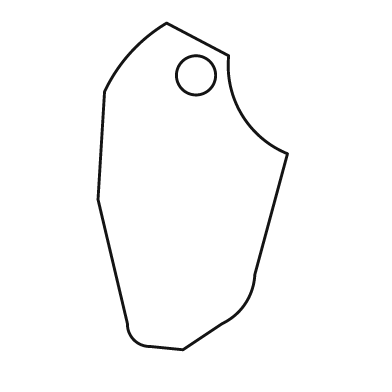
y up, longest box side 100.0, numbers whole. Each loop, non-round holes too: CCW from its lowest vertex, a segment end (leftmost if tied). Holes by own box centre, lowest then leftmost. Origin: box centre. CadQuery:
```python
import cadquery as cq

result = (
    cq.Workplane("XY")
    .moveTo(-3.0, -50.0)
    .lineTo(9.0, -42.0)
    .threePointArc((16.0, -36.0), (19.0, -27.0))
    .lineTo(29.0, 10.0)
    .threePointArc((15.0, 22.0), (11.0, 40.0))
    .lineTo(-8.0, 50.0)
    .threePointArc((-19.0, 41.0), (-27.0, 29.0))
    .lineTo(-29.0, -4.0)
    .lineTo(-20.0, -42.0)
    .threePointArc((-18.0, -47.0), (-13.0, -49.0))
    .close()
    .moveTo(1.0, 34.0)
    .circle(6.0)
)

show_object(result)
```